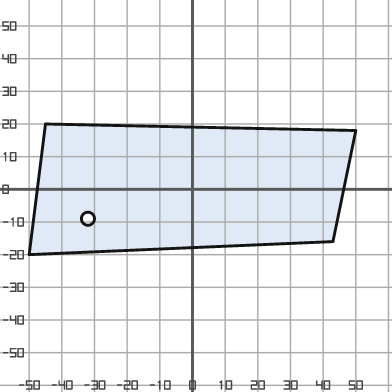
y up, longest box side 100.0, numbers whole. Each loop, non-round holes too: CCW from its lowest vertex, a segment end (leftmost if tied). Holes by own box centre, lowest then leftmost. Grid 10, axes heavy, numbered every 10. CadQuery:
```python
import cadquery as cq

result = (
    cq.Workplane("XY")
    .moveTo(-50.0, -20.0)
    .lineTo(43.0, -16.0)
    .lineTo(50.0, 18.0)
    .lineTo(-45.0, 20.0)
    .close()
    .moveTo(-32.0, -9.0)
    .circle(2.0)
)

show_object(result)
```